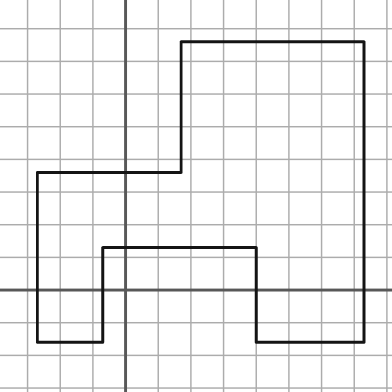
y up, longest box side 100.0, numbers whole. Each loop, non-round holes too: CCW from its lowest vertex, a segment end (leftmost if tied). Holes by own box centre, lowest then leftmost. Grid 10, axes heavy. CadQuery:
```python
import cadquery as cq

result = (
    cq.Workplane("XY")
    .moveTo(-27.0, -16.0)
    .lineTo(-7.0, -16.0)
    .lineTo(-7.0, 13.0)
    .lineTo(40.0, 13.0)
    .lineTo(40.0, -16.0)
    .lineTo(73.0, -16.0)
    .lineTo(73.0, 76.0)
    .lineTo(17.0, 76.0)
    .lineTo(17.0, 36.0)
    .lineTo(-27.0, 36.0)
    .close()
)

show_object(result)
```